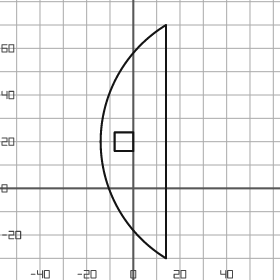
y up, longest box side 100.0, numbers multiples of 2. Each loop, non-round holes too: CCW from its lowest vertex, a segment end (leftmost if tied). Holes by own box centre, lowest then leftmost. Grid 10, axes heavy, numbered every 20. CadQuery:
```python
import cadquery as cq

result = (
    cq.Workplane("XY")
    .moveTo(14.0, -30.0)
    .lineTo(14.0, 70.0)
    .threePointArc((-14.0, 20.0), (14.0, -30.0))
    .close()
    .moveTo(-8.0, 16.0)
    .lineTo(0.0, 16.0)
    .lineTo(0.0, 24.0)
    .lineTo(-8.0, 24.0)
    .close()
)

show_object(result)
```